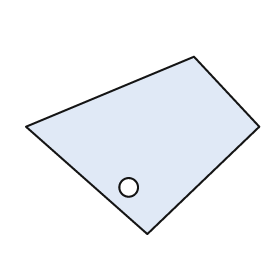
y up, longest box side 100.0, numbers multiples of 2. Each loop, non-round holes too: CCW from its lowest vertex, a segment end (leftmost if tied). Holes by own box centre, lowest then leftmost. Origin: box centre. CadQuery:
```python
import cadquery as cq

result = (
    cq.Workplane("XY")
    .moveTo(2.0, -38.0)
    .lineTo(50.0, 8.0)
    .lineTo(22.0, 38.0)
    .lineTo(-50.0, 8.0)
    .close()
    .moveTo(-6.0, -18.0)
    .circle(4.0)
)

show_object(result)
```